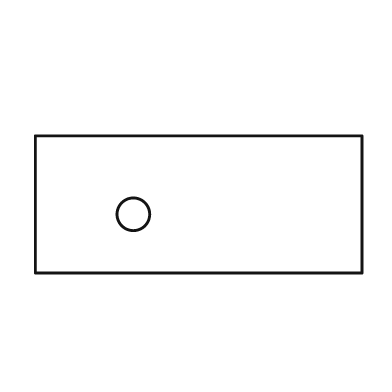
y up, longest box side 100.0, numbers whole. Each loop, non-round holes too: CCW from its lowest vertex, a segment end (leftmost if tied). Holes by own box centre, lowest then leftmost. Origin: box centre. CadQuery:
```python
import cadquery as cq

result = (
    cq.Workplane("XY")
    .moveTo(-50.0, -21.0)
    .lineTo(50.0, -21.0)
    .lineTo(50.0, 21.0)
    .lineTo(-50.0, 21.0)
    .close()
    .moveTo(-20.0, -3.0)
    .circle(5.0)
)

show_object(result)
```